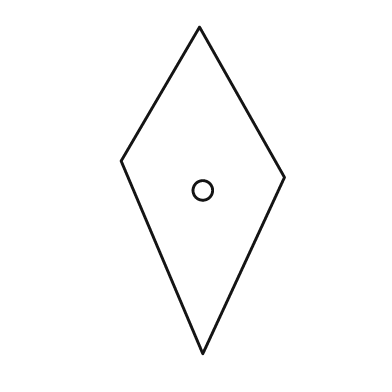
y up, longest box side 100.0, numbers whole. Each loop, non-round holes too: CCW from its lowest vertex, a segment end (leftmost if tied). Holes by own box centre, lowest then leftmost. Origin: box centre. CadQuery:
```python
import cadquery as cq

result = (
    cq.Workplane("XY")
    .moveTo(0.0, -50.0)
    .lineTo(25.0, 4.0)
    .lineTo(-1.0, 50.0)
    .lineTo(-25.0, 9.0)
    .close()
    .moveTo(0.0, 0.0)
    .circle(3.0)
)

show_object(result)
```